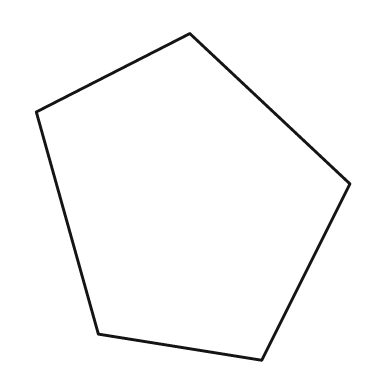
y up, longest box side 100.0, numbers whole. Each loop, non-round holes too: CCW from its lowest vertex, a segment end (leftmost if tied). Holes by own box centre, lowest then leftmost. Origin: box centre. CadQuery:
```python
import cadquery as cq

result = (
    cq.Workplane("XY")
    .moveTo(21.0, -50.0)
    .lineTo(48.0, 4.0)
    .lineTo(-1.0, 50.0)
    .lineTo(-48.0, 26.0)
    .lineTo(-29.0, -42.0)
    .close()
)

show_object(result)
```